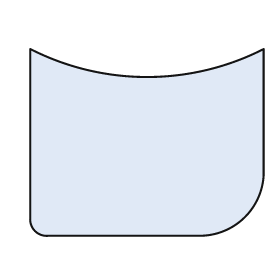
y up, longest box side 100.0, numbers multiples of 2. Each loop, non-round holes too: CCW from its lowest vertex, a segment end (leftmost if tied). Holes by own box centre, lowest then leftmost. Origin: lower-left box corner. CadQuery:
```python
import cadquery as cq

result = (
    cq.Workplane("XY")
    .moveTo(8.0, 0.0)
    .lineTo(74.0, 0.0)
    .threePointArc((92.0, 8.0), (100.0, 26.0))
    .lineTo(100.0, 80.0)
    .threePointArc((50.0, 68.0), (0.0, 80.0))
    .lineTo(0.0, 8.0)
    .threePointArc((2.0, 2.0), (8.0, 0.0))
    .close()
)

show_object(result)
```